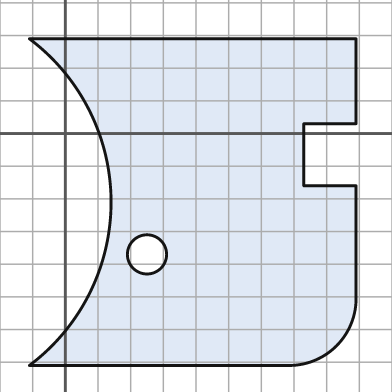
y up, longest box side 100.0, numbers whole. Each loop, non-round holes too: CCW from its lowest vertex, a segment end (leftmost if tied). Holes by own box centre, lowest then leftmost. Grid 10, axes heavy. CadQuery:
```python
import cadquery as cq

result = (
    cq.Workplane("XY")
    .moveTo(-11.0, -71.0)
    .lineTo(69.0, -71.0)
    .threePointArc((83.0, -65.0), (89.0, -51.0))
    .lineTo(89.0, -16.0)
    .lineTo(73.0, -16.0)
    .lineTo(73.0, 3.0)
    .lineTo(89.0, 3.0)
    .lineTo(89.0, 29.0)
    .lineTo(-11.0, 29.0)
    .threePointArc((14.0, -21.0), (-11.0, -71.0))
    .close()
    .moveTo(25.0, -37.0)
    .circle(6.0)
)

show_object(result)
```